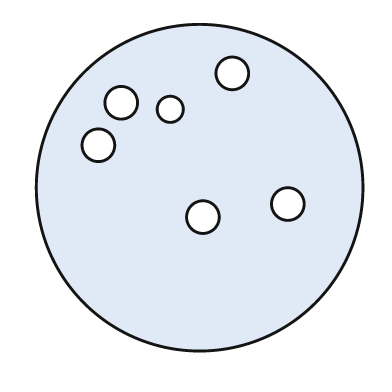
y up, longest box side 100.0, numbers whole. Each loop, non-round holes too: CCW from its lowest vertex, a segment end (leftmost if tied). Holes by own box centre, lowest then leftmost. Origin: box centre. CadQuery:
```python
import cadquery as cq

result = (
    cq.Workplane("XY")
    .moveTo(0.0, 0.0)
    .circle(50.0)
    .moveTo(1.0, -9.0)
    .circle(5.0)
    .moveTo(27.0, -5.0)
    .circle(5.0)
    .moveTo(-31.0, 13.0)
    .circle(5.0)
    .moveTo(-9.0, 24.0)
    .circle(4.0)
    .moveTo(-24.0, 26.0)
    .circle(5.0)
    .moveTo(10.0, 35.0)
    .circle(5.0)
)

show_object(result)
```